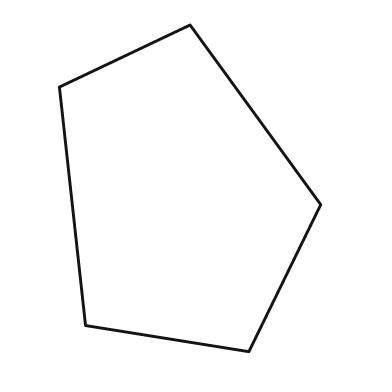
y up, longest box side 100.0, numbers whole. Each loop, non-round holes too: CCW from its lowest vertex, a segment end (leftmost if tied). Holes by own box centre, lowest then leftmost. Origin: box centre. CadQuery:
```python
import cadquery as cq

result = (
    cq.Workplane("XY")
    .moveTo(18.0, -50.0)
    .lineTo(40.0, -5.0)
    .lineTo(0.0, 50.0)
    .lineTo(-40.0, 31.0)
    .lineTo(-32.0, -42.0)
    .close()
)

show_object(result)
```